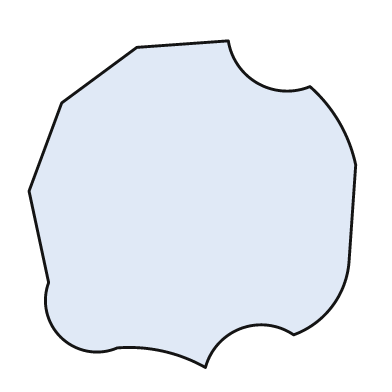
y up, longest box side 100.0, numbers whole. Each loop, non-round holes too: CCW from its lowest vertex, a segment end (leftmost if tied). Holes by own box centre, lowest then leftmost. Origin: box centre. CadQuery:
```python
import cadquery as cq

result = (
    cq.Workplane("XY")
    .moveTo(4.0, -50.0)
    .threePointArc((15.0, -38.0), (31.0, -40.0))
    .threePointArc((43.0, -31.0), (48.0, -17.0))
    .lineTo(50.0, 12.0)
    .threePointArc((45.0, 25.0), (36.0, 36.0))
    .threePointArc((20.0, 37.0), (11.0, 50.0))
    .lineTo(-17.0, 48.0)
    .lineTo(-40.0, 31.0)
    .lineTo(-50.0, 4.0)
    .lineTo(-44.0, -24.0)
    .threePointArc((-40.0, -41.0), (-23.0, -44.0))
    .threePointArc((-9.0, -45.0), (4.0, -50.0))
    .close()
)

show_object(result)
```